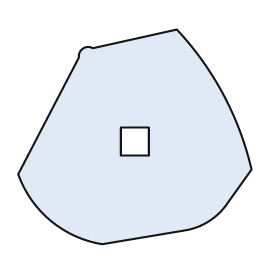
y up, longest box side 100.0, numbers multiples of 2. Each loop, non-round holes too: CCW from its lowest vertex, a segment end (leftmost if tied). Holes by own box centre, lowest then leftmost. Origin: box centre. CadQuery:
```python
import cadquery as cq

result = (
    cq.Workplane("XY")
    .moveTo(-14.0, -46.0)
    .lineTo(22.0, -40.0)
    .threePointArc((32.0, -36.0), (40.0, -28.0))
    .lineTo(50.0, -14.0)
    .threePointArc((38.0, 18.0), (18.0, 46.0))
    .lineTo(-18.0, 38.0)
    .threePointArc((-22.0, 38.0), (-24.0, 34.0))
    .lineTo(-50.0, -16.0)
    .threePointArc((-36.0, -36.0), (-14.0, -46.0))
    .close()
    .moveTo(-6.0, -8.0)
    .lineTo(6.0, -8.0)
    .lineTo(6.0, 4.0)
    .lineTo(-6.0, 4.0)
    .close()
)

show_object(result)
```